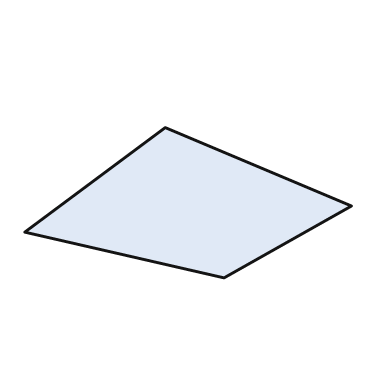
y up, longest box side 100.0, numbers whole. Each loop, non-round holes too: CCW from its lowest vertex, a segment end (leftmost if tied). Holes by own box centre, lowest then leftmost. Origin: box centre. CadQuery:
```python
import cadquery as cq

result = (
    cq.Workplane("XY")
    .moveTo(11.0, -23.0)
    .lineTo(50.0, -1.0)
    .lineTo(-7.0, 23.0)
    .lineTo(-50.0, -9.0)
    .close()
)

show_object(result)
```